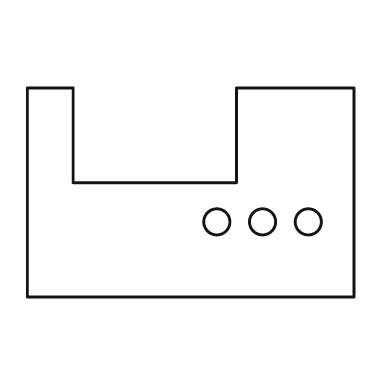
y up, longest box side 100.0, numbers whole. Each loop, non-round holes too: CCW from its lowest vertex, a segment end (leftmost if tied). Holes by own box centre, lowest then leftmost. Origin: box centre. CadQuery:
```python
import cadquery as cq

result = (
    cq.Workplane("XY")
    .moveTo(-50.0, -32.0)
    .lineTo(50.0, -32.0)
    .lineTo(50.0, 32.0)
    .lineTo(14.0, 32.0)
    .lineTo(14.0, 3.0)
    .lineTo(-36.0, 3.0)
    .lineTo(-36.0, 32.0)
    .lineTo(-50.0, 32.0)
    .close()
    .moveTo(8.0, -9.0)
    .circle(4.0)
    .moveTo(22.0, -9.0)
    .circle(4.0)
    .moveTo(36.0, -9.0)
    .circle(4.0)
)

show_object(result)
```